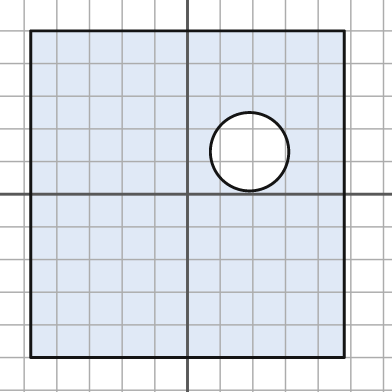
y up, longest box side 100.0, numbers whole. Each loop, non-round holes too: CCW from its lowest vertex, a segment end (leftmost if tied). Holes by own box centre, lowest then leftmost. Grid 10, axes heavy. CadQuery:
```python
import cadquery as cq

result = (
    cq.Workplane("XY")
    .moveTo(-48.0, -50.0)
    .lineTo(48.0, -50.0)
    .lineTo(48.0, 50.0)
    .lineTo(-48.0, 50.0)
    .close()
    .moveTo(19.0, 13.0)
    .circle(12.0)
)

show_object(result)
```